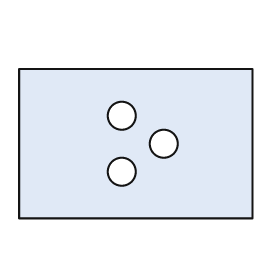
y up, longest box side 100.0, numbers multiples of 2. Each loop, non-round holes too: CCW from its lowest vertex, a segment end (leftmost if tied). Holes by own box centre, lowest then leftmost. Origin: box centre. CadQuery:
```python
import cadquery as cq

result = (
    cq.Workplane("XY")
    .moveTo(-50.0, -32.0)
    .lineTo(50.0, -32.0)
    .lineTo(50.0, 32.0)
    .lineTo(-50.0, 32.0)
    .close()
    .moveTo(-6.0, -12.0)
    .circle(6.0)
    .moveTo(12.0, 0.0)
    .circle(6.0)
    .moveTo(-6.0, 12.0)
    .circle(6.0)
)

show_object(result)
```